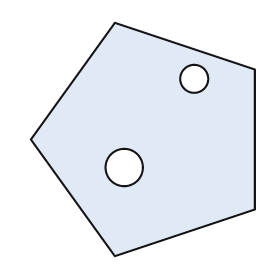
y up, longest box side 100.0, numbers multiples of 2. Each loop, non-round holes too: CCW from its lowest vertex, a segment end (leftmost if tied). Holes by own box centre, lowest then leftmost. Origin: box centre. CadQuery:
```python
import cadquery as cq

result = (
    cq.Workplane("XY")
    .moveTo(-12.0, -50.0)
    .lineTo(48.0, -30.0)
    .lineTo(48.0, 30.0)
    .lineTo(-12.0, 50.0)
    .lineTo(-48.0, 0.0)
    .close()
    .moveTo(-8.0, -12.0)
    .circle(8.0)
    .moveTo(22.0, 26.0)
    .circle(6.0)
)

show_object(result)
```